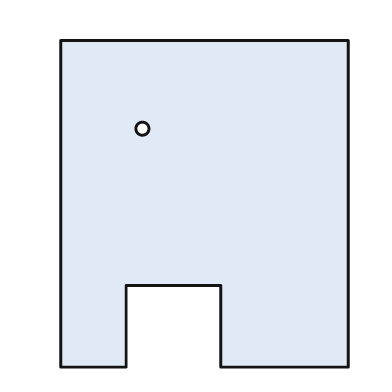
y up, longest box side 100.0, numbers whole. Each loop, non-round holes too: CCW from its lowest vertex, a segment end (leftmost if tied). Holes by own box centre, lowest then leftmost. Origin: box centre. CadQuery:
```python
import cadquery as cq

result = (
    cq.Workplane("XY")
    .moveTo(-44.0, -50.0)
    .lineTo(-24.0, -50.0)
    .lineTo(-24.0, -25.0)
    .lineTo(5.0, -25.0)
    .lineTo(5.0, -50.0)
    .lineTo(44.0, -50.0)
    .lineTo(44.0, 50.0)
    .lineTo(-44.0, 50.0)
    .close()
    .moveTo(-19.0, 23.0)
    .circle(2.0)
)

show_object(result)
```